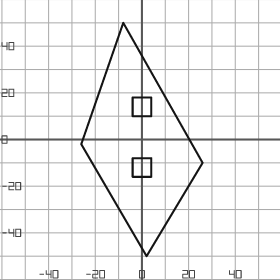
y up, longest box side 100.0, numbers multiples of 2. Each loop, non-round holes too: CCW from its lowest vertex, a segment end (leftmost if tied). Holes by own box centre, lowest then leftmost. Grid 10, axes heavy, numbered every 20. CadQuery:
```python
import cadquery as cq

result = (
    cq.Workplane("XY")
    .moveTo(2.0, -50.0)
    .lineTo(26.0, -10.0)
    .lineTo(-8.0, 50.0)
    .lineTo(-26.0, -2.0)
    .close()
    .moveTo(-4.0, -16.0)
    .lineTo(4.0, -16.0)
    .lineTo(4.0, -8.0)
    .lineTo(-4.0, -8.0)
    .close()
    .moveTo(-4.0, 10.0)
    .lineTo(4.0, 10.0)
    .lineTo(4.0, 18.0)
    .lineTo(-4.0, 18.0)
    .close()
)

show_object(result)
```